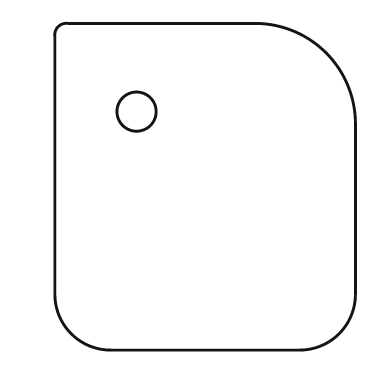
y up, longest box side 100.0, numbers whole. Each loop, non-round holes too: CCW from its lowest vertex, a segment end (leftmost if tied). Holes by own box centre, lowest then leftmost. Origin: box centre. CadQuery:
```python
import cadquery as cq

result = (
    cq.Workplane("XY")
    .moveTo(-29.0, -50.0)
    .lineTo(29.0, -50.0)
    .threePointArc((41.0, -45.0), (46.0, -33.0))
    .lineTo(46.0, 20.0)
    .threePointArc((37.0, 41.0), (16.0, 50.0))
    .lineTo(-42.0, 50.0)
    .threePointArc((-45.0, 49.0), (-46.0, 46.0))
    .lineTo(-46.0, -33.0)
    .threePointArc((-41.0, -45.0), (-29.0, -50.0))
    .close()
    .moveTo(-21.0, 23.0)
    .circle(6.0)
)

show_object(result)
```